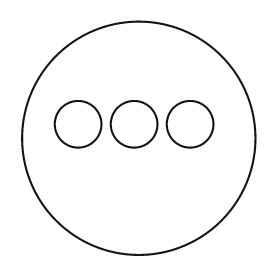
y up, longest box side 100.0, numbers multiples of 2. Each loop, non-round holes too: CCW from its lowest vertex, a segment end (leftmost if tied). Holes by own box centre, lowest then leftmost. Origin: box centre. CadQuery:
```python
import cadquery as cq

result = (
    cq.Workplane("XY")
    .moveTo(0.0, 0.0)
    .circle(50.0)
    .moveTo(-26.0, 6.0)
    .circle(10.0)
    .moveTo(-2.0, 6.0)
    .circle(10.0)
    .moveTo(22.0, 6.0)
    .circle(10.0)
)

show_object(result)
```